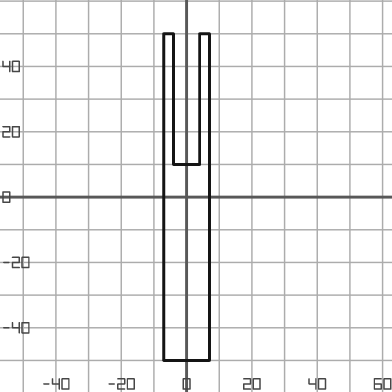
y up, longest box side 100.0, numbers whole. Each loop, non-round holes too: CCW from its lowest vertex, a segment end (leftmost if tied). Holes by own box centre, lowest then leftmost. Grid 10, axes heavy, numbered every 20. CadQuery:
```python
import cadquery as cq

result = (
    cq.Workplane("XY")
    .moveTo(-7.0, -50.0)
    .lineTo(7.0, -50.0)
    .lineTo(7.0, 50.0)
    .lineTo(4.0, 50.0)
    .lineTo(4.0, 10.0)
    .lineTo(-4.0, 10.0)
    .lineTo(-4.0, 50.0)
    .lineTo(-7.0, 50.0)
    .close()
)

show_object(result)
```